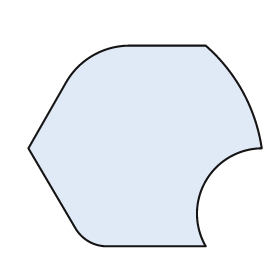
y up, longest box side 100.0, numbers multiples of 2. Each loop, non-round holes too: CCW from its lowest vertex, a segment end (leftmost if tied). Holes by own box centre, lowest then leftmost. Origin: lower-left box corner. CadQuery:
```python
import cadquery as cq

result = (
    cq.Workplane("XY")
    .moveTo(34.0, 0.0)
    .lineTo(76.0, 0.0)
    .threePointArc((76.0, 28.0), (100.0, 42.0))
    .threePointArc((92.0, 66.0), (76.0, 86.0))
    .lineTo(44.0, 86.0)
    .threePointArc((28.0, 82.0), (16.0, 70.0))
    .lineTo(0.0, 42.0)
    .lineTo(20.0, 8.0)
    .threePointArc((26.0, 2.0), (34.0, 0.0))
    .close()
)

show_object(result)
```